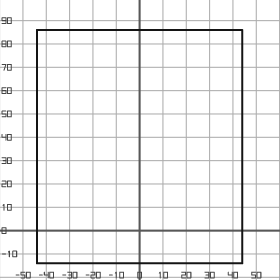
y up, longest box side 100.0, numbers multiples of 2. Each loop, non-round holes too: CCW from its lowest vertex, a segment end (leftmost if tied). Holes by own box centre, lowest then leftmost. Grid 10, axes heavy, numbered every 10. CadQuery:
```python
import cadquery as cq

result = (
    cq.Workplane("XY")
    .moveTo(-44.0, -14.0)
    .lineTo(44.0, -14.0)
    .lineTo(44.0, 86.0)
    .lineTo(-44.0, 86.0)
    .close()
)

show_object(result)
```